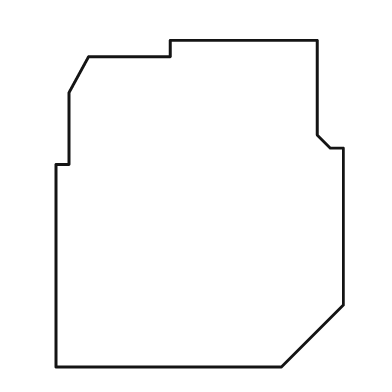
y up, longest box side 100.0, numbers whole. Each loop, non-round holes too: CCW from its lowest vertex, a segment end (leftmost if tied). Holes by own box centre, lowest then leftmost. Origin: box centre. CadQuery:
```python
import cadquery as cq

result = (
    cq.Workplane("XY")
    .moveTo(-44.0, -50.0)
    .lineTo(25.0, -50.0)
    .lineTo(44.0, -31.0)
    .lineTo(44.0, 17.0)
    .lineTo(40.0, 17.0)
    .lineTo(36.0, 21.0)
    .lineTo(36.0, 50.0)
    .lineTo(-9.0, 50.0)
    .lineTo(-9.0, 45.0)
    .lineTo(-34.0, 45.0)
    .lineTo(-40.0, 34.0)
    .lineTo(-40.0, 12.0)
    .lineTo(-44.0, 12.0)
    .close()
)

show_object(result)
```